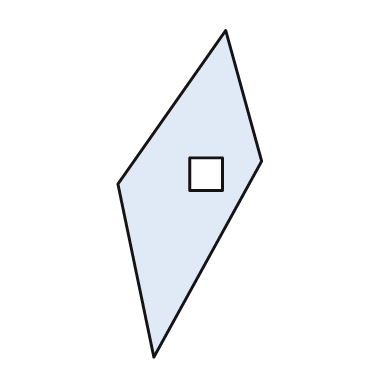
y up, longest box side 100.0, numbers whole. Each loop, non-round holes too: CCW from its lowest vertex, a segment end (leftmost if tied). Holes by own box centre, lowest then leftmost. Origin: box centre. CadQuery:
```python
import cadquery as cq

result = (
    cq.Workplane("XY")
    .moveTo(-11.0, -50.0)
    .lineTo(22.0, 10.0)
    .lineTo(11.0, 50.0)
    .lineTo(-22.0, 3.0)
    .close()
    .moveTo(0.0, 1.0)
    .lineTo(10.0, 1.0)
    .lineTo(10.0, 11.0)
    .lineTo(0.0, 11.0)
    .close()
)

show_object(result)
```